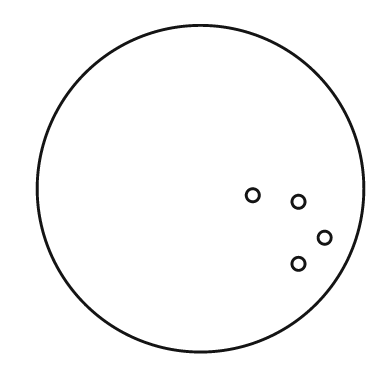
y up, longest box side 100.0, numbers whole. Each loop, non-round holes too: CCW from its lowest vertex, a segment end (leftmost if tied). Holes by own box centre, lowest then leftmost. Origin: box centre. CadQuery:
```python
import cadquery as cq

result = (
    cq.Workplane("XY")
    .moveTo(0.0, 0.0)
    .circle(50.0)
    .moveTo(30.0, -23.0)
    .circle(2.0)
    .moveTo(38.0, -15.0)
    .circle(2.0)
    .moveTo(30.0, -4.0)
    .circle(2.0)
    .moveTo(16.0, -2.0)
    .circle(2.0)
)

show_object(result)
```